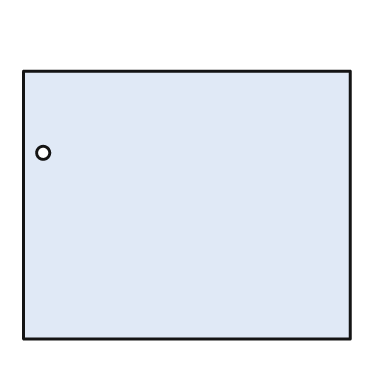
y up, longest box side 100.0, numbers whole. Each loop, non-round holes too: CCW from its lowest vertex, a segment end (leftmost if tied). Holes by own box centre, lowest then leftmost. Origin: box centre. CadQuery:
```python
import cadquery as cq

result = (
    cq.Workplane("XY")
    .moveTo(-50.0, -41.0)
    .lineTo(50.0, -41.0)
    .lineTo(50.0, 41.0)
    .lineTo(-50.0, 41.0)
    .close()
    .moveTo(-44.0, 16.0)
    .circle(2.0)
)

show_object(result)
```